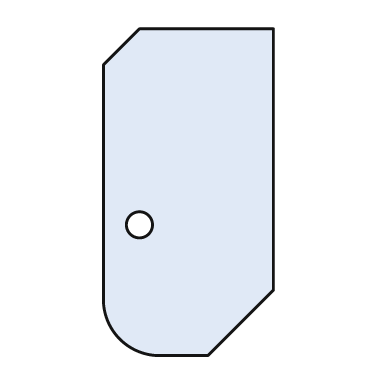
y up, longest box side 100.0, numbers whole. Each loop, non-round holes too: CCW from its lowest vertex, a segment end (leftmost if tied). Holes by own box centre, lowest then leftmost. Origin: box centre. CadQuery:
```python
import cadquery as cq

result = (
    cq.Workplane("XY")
    .moveTo(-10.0, -50.0)
    .lineTo(6.0, -50.0)
    .lineTo(26.0, -30.0)
    .lineTo(26.0, 50.0)
    .lineTo(-15.0, 50.0)
    .lineTo(-26.0, 39.0)
    .lineTo(-26.0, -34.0)
    .threePointArc((-21.0, -45.0), (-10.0, -50.0))
    .close()
    .moveTo(-15.0, -10.0)
    .circle(4.0)
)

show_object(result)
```